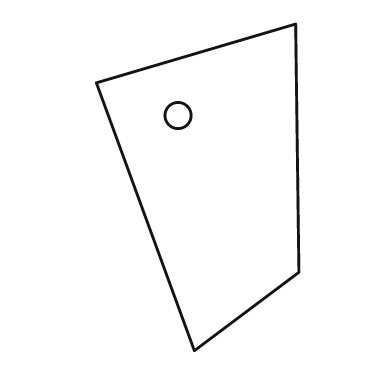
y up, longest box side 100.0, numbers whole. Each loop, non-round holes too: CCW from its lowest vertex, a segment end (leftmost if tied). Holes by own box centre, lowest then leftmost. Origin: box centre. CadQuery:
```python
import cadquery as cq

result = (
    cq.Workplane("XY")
    .moveTo(-1.0, -50.0)
    .lineTo(31.0, -26.0)
    .lineTo(30.0, 50.0)
    .lineTo(-31.0, 32.0)
    .close()
    .moveTo(-6.0, 22.0)
    .circle(4.0)
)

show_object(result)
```